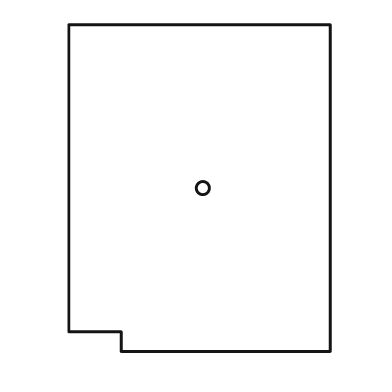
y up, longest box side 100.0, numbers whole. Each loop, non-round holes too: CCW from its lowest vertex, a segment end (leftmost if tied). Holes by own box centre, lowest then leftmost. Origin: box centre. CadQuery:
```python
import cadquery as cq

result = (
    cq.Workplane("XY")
    .moveTo(-24.0, -50.0)
    .lineTo(40.0, -50.0)
    .lineTo(40.0, 50.0)
    .lineTo(-40.0, 50.0)
    .lineTo(-40.0, -44.0)
    .lineTo(-24.0, -44.0)
    .close()
    .moveTo(1.0, 0.0)
    .circle(2.0)
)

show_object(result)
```